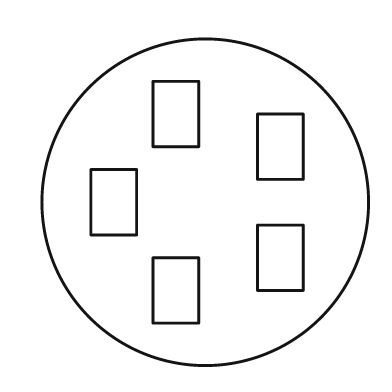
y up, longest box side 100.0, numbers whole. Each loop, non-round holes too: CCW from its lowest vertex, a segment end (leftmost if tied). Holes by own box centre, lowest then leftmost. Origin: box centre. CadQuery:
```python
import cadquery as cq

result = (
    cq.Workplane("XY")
    .moveTo(0.0, 0.0)
    .circle(50.0)
    .moveTo(-16.0, -37.0)
    .lineTo(-2.0, -37.0)
    .lineTo(-2.0, -17.0)
    .lineTo(-16.0, -17.0)
    .close()
    .moveTo(16.0, -27.0)
    .lineTo(30.0, -27.0)
    .lineTo(30.0, -7.0)
    .lineTo(16.0, -7.0)
    .close()
    .moveTo(-35.0, -10.0)
    .lineTo(-21.0, -10.0)
    .lineTo(-21.0, 10.0)
    .lineTo(-35.0, 10.0)
    .close()
    .moveTo(16.0, 7.0)
    .lineTo(30.0, 7.0)
    .lineTo(30.0, 27.0)
    .lineTo(16.0, 27.0)
    .close()
    .moveTo(-16.0, 17.0)
    .lineTo(-2.0, 17.0)
    .lineTo(-2.0, 37.0)
    .lineTo(-16.0, 37.0)
    .close()
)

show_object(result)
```